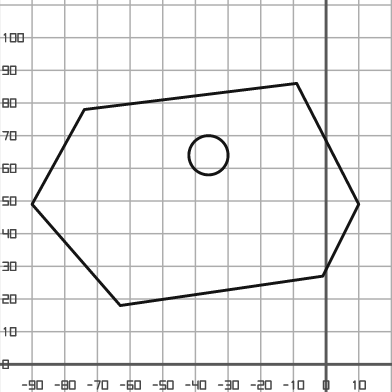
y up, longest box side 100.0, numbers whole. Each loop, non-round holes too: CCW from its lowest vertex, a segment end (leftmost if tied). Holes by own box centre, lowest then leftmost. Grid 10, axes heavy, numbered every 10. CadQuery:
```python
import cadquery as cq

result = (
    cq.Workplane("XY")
    .moveTo(-63.0, 18.0)
    .lineTo(-1.0, 27.0)
    .lineTo(10.0, 49.0)
    .lineTo(-9.0, 86.0)
    .lineTo(-74.0, 78.0)
    .lineTo(-90.0, 49.0)
    .close()
    .moveTo(-36.0, 64.0)
    .circle(6.0)
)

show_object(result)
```